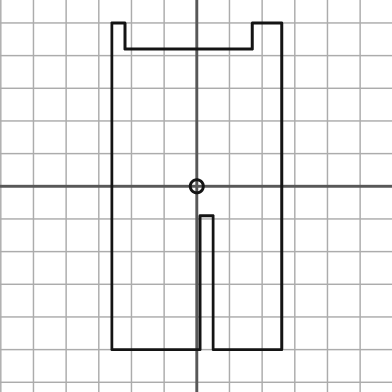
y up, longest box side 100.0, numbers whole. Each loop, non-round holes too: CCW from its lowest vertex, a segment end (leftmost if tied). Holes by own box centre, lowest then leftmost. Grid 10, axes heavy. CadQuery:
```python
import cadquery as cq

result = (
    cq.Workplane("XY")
    .moveTo(-26.0, -50.0)
    .lineTo(1.0, -50.0)
    .lineTo(1.0, -9.0)
    .lineTo(5.0, -9.0)
    .lineTo(5.0, -50.0)
    .lineTo(26.0, -50.0)
    .lineTo(26.0, 50.0)
    .lineTo(17.0, 50.0)
    .lineTo(17.0, 42.0)
    .lineTo(-22.0, 42.0)
    .lineTo(-22.0, 50.0)
    .lineTo(-26.0, 50.0)
    .close()
    .moveTo(0.0, 0.0)
    .circle(2.0)
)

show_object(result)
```